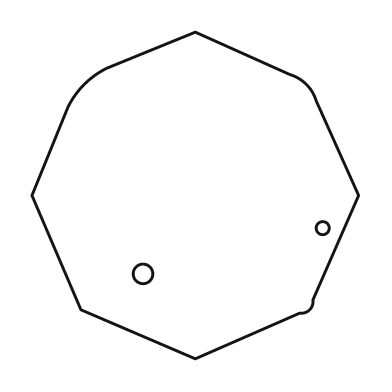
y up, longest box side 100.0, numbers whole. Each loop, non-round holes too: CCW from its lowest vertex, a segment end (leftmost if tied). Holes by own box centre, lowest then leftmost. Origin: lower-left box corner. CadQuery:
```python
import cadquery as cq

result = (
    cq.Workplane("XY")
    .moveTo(50.0, 0.0)
    .lineTo(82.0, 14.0)
    .threePointArc((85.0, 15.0), (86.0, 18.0))
    .lineTo(100.0, 50.0)
    .lineTo(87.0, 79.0)
    .threePointArc((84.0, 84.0), (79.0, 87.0))
    .lineTo(50.0, 100.0)
    .lineTo(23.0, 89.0)
    .threePointArc((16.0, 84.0), (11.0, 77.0))
    .lineTo(0.0, 50.0)
    .lineTo(15.0, 15.0)
    .close()
    .moveTo(34.0, 26.0)
    .circle(3.0)
    .moveTo(89.0, 40.0)
    .circle(2.0)
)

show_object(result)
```